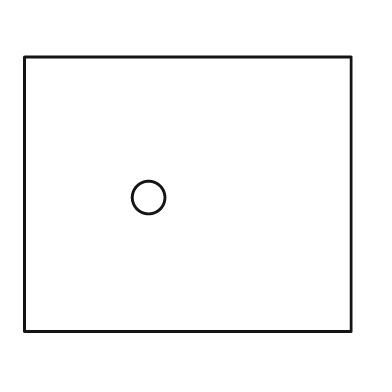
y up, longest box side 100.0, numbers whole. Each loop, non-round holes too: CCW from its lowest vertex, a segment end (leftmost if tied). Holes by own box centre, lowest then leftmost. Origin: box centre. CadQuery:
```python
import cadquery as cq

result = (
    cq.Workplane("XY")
    .moveTo(-50.0, -42.0)
    .lineTo(50.0, -42.0)
    .lineTo(50.0, 42.0)
    .lineTo(-50.0, 42.0)
    .close()
    .moveTo(-12.0, -1.0)
    .circle(5.0)
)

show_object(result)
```